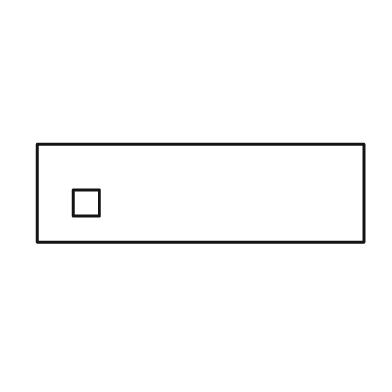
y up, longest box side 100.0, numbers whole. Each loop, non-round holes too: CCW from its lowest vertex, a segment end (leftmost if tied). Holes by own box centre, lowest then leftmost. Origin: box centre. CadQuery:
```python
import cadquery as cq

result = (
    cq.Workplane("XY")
    .moveTo(-50.0, -15.0)
    .lineTo(50.0, -15.0)
    .lineTo(50.0, 15.0)
    .lineTo(-50.0, 15.0)
    .close()
    .moveTo(-39.0, -7.0)
    .lineTo(-31.0, -7.0)
    .lineTo(-31.0, 1.0)
    .lineTo(-39.0, 1.0)
    .close()
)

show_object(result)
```